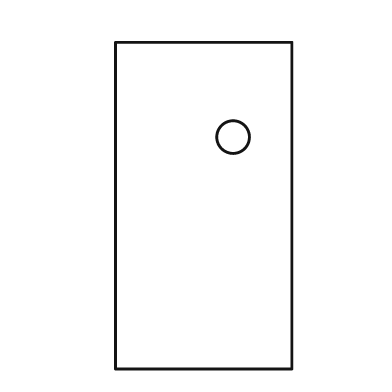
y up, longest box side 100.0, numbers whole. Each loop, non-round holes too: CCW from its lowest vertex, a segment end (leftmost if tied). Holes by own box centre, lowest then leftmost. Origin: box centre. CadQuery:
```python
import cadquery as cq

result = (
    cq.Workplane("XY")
    .moveTo(-27.0, -50.0)
    .lineTo(27.0, -50.0)
    .lineTo(27.0, 50.0)
    .lineTo(-27.0, 50.0)
    .close()
    .moveTo(9.0, 21.0)
    .circle(5.0)
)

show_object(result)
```